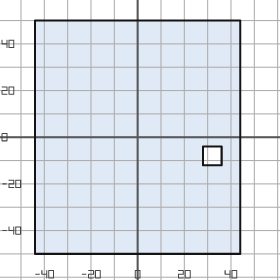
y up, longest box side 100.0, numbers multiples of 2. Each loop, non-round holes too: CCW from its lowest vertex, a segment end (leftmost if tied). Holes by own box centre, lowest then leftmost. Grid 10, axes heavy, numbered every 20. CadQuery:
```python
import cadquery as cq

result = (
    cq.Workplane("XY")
    .moveTo(-44.0, -50.0)
    .lineTo(44.0, -50.0)
    .lineTo(44.0, 50.0)
    .lineTo(-44.0, 50.0)
    .close()
    .moveTo(28.0, -12.0)
    .lineTo(36.0, -12.0)
    .lineTo(36.0, -4.0)
    .lineTo(28.0, -4.0)
    .close()
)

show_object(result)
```